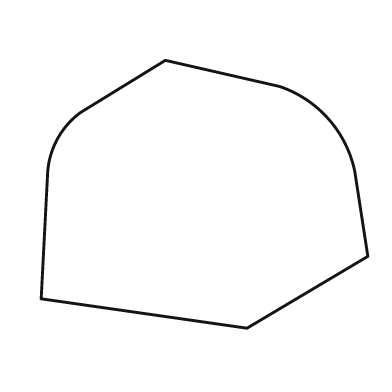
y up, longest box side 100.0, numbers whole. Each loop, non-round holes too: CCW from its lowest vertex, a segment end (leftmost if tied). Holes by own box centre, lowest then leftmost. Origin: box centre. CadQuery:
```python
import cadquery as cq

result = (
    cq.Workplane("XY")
    .moveTo(13.0, -41.0)
    .lineTo(50.0, -19.0)
    .lineTo(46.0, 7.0)
    .threePointArc((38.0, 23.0), (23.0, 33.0))
    .lineTo(-12.0, 41.0)
    .lineTo(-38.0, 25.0)
    .threePointArc((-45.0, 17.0), (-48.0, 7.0))
    .lineTo(-50.0, -32.0)
    .close()
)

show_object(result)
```